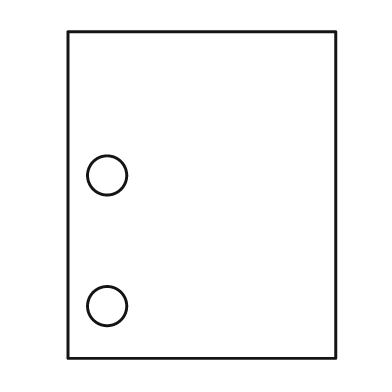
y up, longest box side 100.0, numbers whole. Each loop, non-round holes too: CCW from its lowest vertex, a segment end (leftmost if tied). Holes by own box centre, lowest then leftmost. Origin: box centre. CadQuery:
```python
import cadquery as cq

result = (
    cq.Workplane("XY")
    .moveTo(-41.0, -50.0)
    .lineTo(41.0, -50.0)
    .lineTo(41.0, 50.0)
    .lineTo(-41.0, 50.0)
    .close()
    .moveTo(-29.0, -34.0)
    .circle(6.0)
    .moveTo(-29.0, 6.0)
    .circle(6.0)
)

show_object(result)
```